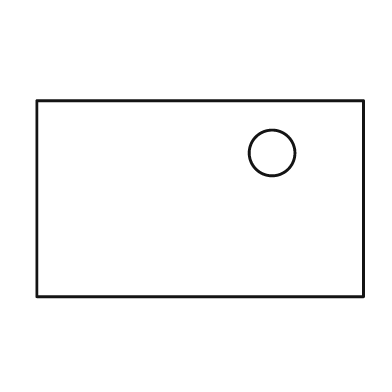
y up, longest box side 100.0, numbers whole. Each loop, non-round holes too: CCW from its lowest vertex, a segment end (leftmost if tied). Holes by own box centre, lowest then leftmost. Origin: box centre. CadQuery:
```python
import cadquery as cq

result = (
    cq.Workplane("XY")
    .moveTo(-50.0, -30.0)
    .lineTo(50.0, -30.0)
    .lineTo(50.0, 30.0)
    .lineTo(-50.0, 30.0)
    .close()
    .moveTo(22.0, 14.0)
    .circle(7.0)
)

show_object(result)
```